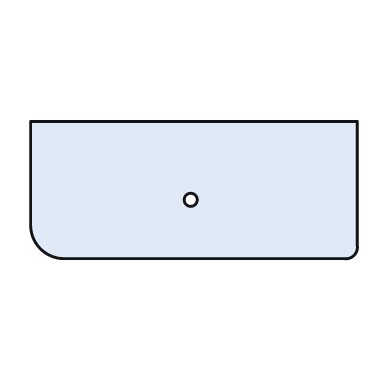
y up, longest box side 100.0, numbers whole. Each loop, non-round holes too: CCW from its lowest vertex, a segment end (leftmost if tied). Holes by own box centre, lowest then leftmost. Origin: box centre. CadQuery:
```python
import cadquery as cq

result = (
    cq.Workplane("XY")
    .moveTo(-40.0, -21.0)
    .lineTo(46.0, -21.0)
    .threePointArc((49.0, -20.0), (50.0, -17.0))
    .lineTo(50.0, 21.0)
    .lineTo(-50.0, 21.0)
    .lineTo(-50.0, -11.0)
    .threePointArc((-47.0, -18.0), (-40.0, -21.0))
    .close()
    .moveTo(-1.0, -3.0)
    .circle(2.0)
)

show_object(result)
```